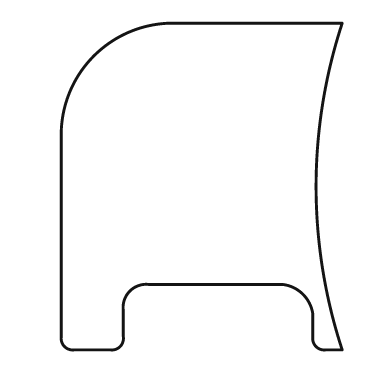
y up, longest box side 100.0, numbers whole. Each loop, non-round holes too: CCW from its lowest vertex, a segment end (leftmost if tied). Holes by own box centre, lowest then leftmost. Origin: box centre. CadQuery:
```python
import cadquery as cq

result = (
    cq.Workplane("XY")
    .moveTo(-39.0, -50.0)
    .lineTo(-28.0, -50.0)
    .threePointArc((-25.0, -49.0), (-24.0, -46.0))
    .lineTo(-24.0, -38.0)
    .threePointArc((-22.0, -32.0), (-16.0, -30.0))
    .lineTo(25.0, -30.0)
    .threePointArc((31.0, -33.0), (34.0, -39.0))
    .lineTo(34.0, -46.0)
    .threePointArc((35.0, -49.0), (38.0, -50.0))
    .lineTo(43.0, -50.0)
    .threePointArc((35.0, 0.0), (43.0, 50.0))
    .lineTo(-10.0, 50.0)
    .threePointArc((-33.0, 40.0), (-43.0, 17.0))
    .lineTo(-43.0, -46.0)
    .threePointArc((-42.0, -49.0), (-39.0, -50.0))
    .close()
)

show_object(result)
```